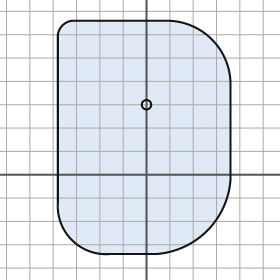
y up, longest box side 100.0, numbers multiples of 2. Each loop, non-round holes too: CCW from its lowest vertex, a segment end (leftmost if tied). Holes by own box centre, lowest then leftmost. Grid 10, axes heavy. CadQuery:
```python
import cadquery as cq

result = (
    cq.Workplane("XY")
    .moveTo(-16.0, -34.0)
    .lineTo(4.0, -34.0)
    .threePointArc((26.0, -24.0), (36.0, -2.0))
    .lineTo(36.0, 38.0)
    .threePointArc((28.0, 58.0), (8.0, 66.0))
    .lineTo(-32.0, 66.0)
    .threePointArc((-36.0, 64.0), (-38.0, 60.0))
    .lineTo(-38.0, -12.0)
    .threePointArc((-32.0, -28.0), (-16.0, -34.0))
    .close()
    .moveTo(0.0, 30.0)
    .circle(2.0)
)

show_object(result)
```